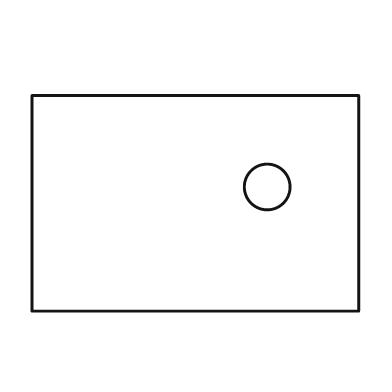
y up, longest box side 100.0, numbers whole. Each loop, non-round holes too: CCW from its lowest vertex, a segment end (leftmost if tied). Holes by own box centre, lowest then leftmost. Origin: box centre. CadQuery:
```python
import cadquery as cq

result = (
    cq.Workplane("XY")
    .moveTo(-50.0, -33.0)
    .lineTo(50.0, -33.0)
    .lineTo(50.0, 33.0)
    .lineTo(-50.0, 33.0)
    .close()
    .moveTo(22.0, 5.0)
    .circle(7.0)
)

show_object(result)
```